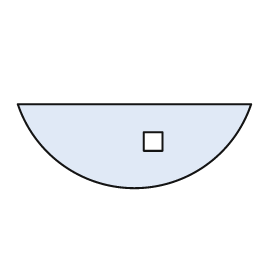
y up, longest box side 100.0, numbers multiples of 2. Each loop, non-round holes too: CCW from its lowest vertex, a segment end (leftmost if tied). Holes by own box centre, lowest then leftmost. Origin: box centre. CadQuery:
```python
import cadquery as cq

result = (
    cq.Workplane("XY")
    .moveTo(-50.0, 18.0)
    .threePointArc((0.0, -18.0), (50.0, 18.0))
    .close()
    .moveTo(4.0, -2.0)
    .lineTo(12.0, -2.0)
    .lineTo(12.0, 6.0)
    .lineTo(4.0, 6.0)
    .close()
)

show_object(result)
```